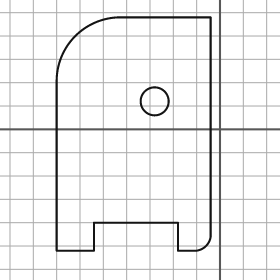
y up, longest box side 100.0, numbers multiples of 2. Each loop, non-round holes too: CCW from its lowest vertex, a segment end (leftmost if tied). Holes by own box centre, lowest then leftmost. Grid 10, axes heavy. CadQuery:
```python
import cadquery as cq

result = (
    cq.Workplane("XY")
    .moveTo(-70.0, -52.0)
    .lineTo(-54.0, -52.0)
    .lineTo(-54.0, -40.0)
    .lineTo(-18.0, -40.0)
    .lineTo(-18.0, -52.0)
    .lineTo(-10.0, -52.0)
    .threePointArc((-6.0, -50.0), (-4.0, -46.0))
    .lineTo(-4.0, 48.0)
    .lineTo(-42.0, 48.0)
    .threePointArc((-62.0, 40.0), (-70.0, 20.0))
    .close()
    .moveTo(-28.0, 12.0)
    .circle(6.0)
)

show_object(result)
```